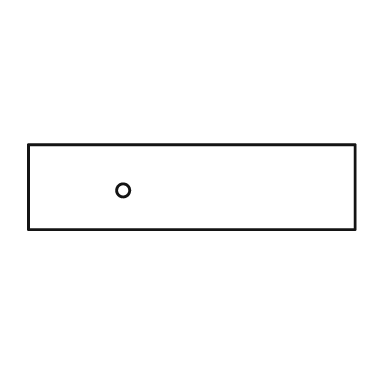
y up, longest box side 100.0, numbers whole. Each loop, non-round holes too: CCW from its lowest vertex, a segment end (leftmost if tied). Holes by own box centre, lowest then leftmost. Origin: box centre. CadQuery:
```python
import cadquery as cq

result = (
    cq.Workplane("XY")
    .moveTo(-50.0, -13.0)
    .lineTo(50.0, -13.0)
    .lineTo(50.0, 13.0)
    .lineTo(-50.0, 13.0)
    .close()
    .moveTo(-21.0, -1.0)
    .circle(2.0)
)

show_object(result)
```